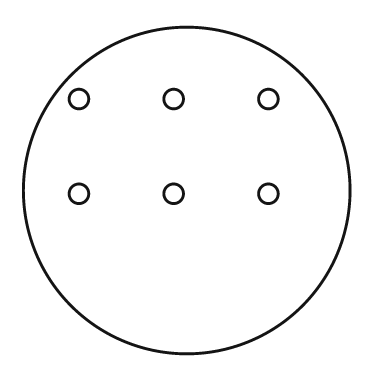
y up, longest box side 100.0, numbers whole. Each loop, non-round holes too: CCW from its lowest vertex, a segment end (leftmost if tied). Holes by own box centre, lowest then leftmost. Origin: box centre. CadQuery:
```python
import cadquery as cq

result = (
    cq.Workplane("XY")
    .moveTo(0.0, 0.0)
    .circle(50.0)
    .moveTo(-33.0, -1.0)
    .circle(3.0)
    .moveTo(-4.0, -1.0)
    .circle(3.0)
    .moveTo(25.0, -1.0)
    .circle(3.0)
    .moveTo(-33.0, 28.0)
    .circle(3.0)
    .moveTo(-4.0, 28.0)
    .circle(3.0)
    .moveTo(25.0, 28.0)
    .circle(3.0)
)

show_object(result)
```